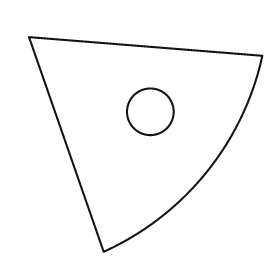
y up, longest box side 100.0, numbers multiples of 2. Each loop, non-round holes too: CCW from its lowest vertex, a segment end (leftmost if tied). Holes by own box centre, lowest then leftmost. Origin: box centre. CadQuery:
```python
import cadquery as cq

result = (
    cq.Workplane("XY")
    .moveTo(-18.0, -46.0)
    .threePointArc((26.0, -12.0), (50.0, 38.0))
    .lineTo(-50.0, 46.0)
    .close()
    .moveTo(2.0, 14.0)
    .circle(10.0)
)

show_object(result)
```